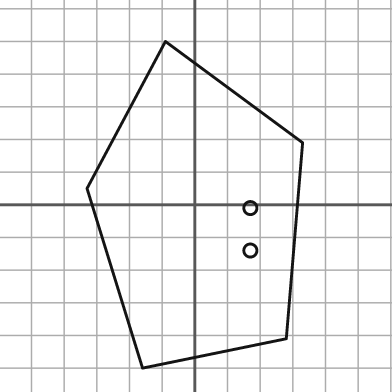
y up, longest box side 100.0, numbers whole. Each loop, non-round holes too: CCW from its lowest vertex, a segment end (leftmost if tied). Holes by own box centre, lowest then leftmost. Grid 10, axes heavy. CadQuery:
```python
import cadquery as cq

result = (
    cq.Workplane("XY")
    .moveTo(-16.0, -50.0)
    .lineTo(28.0, -41.0)
    .lineTo(33.0, 19.0)
    .lineTo(-9.0, 50.0)
    .lineTo(-33.0, 5.0)
    .close()
    .moveTo(17.0, -14.0)
    .circle(2.0)
    .moveTo(17.0, -1.0)
    .circle(2.0)
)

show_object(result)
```